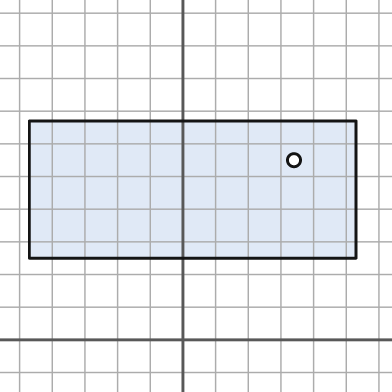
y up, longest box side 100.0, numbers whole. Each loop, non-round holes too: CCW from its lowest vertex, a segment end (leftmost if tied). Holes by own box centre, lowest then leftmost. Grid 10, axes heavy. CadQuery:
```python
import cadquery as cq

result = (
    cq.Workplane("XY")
    .moveTo(-47.0, 25.0)
    .lineTo(53.0, 25.0)
    .lineTo(53.0, 67.0)
    .lineTo(-47.0, 67.0)
    .close()
    .moveTo(34.0, 55.0)
    .circle(2.0)
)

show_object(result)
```